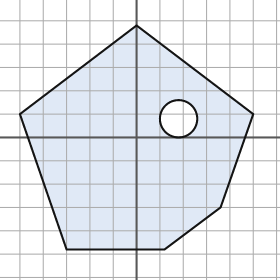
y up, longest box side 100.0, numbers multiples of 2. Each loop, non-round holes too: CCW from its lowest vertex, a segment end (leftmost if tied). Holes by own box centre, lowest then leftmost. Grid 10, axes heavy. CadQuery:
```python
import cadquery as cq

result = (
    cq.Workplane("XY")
    .moveTo(-30.0, -48.0)
    .lineTo(12.0, -48.0)
    .lineTo(36.0, -30.0)
    .lineTo(50.0, 10.0)
    .lineTo(0.0, 48.0)
    .lineTo(-50.0, 10.0)
    .close()
    .moveTo(18.0, 8.0)
    .circle(8.0)
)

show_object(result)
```